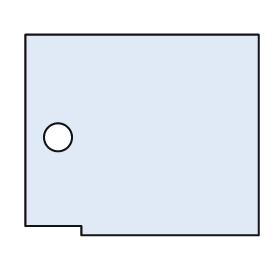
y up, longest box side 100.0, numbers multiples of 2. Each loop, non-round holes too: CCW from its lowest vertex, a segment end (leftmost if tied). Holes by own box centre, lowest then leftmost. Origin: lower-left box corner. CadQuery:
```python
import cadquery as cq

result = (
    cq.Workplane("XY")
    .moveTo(24.0, 0.0)
    .lineTo(100.0, 0.0)
    .lineTo(100.0, 86.0)
    .lineTo(0.0, 86.0)
    .lineTo(0.0, 4.0)
    .lineTo(24.0, 4.0)
    .close()
    .moveTo(14.0, 42.0)
    .circle(6.0)
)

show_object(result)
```